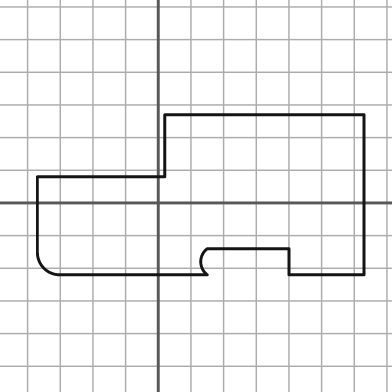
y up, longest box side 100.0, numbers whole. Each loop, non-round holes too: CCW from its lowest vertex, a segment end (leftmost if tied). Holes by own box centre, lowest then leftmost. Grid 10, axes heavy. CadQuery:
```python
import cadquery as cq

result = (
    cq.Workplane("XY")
    .moveTo(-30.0, -22.0)
    .lineTo(15.0, -22.0)
    .threePointArc((13.0, -18.0), (15.0, -14.0))
    .lineTo(40.0, -14.0)
    .lineTo(40.0, -22.0)
    .lineTo(63.0, -22.0)
    .lineTo(63.0, 27.0)
    .lineTo(2.0, 27.0)
    .lineTo(2.0, 8.0)
    .lineTo(-37.0, 8.0)
    .lineTo(-37.0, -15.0)
    .threePointArc((-35.0, -20.0), (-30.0, -22.0))
    .close()
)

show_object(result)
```